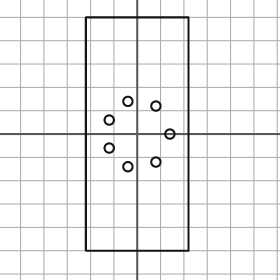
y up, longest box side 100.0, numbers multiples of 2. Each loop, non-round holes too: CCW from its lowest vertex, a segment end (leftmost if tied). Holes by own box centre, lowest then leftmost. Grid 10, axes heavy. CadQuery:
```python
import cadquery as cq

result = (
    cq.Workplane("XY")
    .moveTo(-22.0, -50.0)
    .lineTo(22.0, -50.0)
    .lineTo(22.0, 50.0)
    .lineTo(-22.0, 50.0)
    .close()
    .moveTo(-4.0, -14.0)
    .circle(2.0)
    .moveTo(8.0, -12.0)
    .circle(2.0)
    .moveTo(-12.0, -6.0)
    .circle(2.0)
    .moveTo(14.0, 0.0)
    .circle(2.0)
    .moveTo(-12.0, 6.0)
    .circle(2.0)
    .moveTo(8.0, 12.0)
    .circle(2.0)
    .moveTo(-4.0, 14.0)
    .circle(2.0)
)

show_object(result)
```